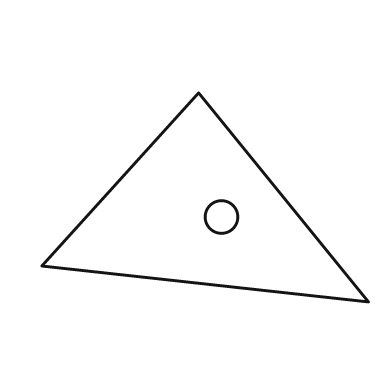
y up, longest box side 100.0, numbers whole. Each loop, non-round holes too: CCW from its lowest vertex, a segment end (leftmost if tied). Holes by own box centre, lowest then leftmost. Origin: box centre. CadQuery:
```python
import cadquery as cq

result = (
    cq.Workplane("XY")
    .moveTo(50.0, -32.0)
    .lineTo(-2.0, 32.0)
    .lineTo(-50.0, -21.0)
    .close()
    .moveTo(5.0, -6.0)
    .circle(5.0)
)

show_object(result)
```